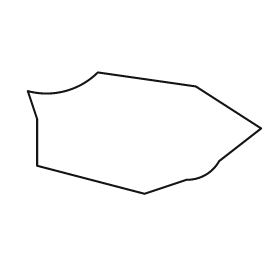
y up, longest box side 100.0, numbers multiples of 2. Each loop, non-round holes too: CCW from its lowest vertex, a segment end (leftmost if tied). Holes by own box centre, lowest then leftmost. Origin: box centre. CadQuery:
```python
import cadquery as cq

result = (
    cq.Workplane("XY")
    .moveTo(0.0, -26.0)
    .lineTo(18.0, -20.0)
    .threePointArc((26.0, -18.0), (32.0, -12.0))
    .lineTo(50.0, 2.0)
    .lineTo(22.0, 20.0)
    .lineTo(-20.0, 26.0)
    .threePointArc((-34.0, 18.0), (-50.0, 18.0))
    .lineTo(-46.0, 6.0)
    .lineTo(-46.0, -14.0)
    .close()
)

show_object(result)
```